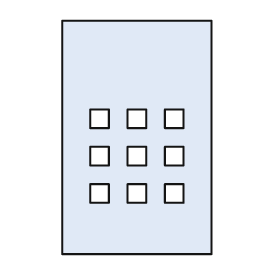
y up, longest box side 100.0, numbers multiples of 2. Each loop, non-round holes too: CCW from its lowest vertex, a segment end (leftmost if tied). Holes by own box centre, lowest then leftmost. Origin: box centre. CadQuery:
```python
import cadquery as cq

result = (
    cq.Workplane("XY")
    .moveTo(-32.0, -50.0)
    .lineTo(32.0, -50.0)
    .lineTo(32.0, 50.0)
    .lineTo(-32.0, 50.0)
    .close()
    .moveTo(-20.0, -28.0)
    .lineTo(-12.0, -28.0)
    .lineTo(-12.0, -20.0)
    .lineTo(-20.0, -20.0)
    .close()
    .moveTo(-4.0, -28.0)
    .lineTo(4.0, -28.0)
    .lineTo(4.0, -20.0)
    .lineTo(-4.0, -20.0)
    .close()
    .moveTo(12.0, -28.0)
    .lineTo(20.0, -28.0)
    .lineTo(20.0, -20.0)
    .lineTo(12.0, -20.0)
    .close()
    .moveTo(-20.0, -12.0)
    .lineTo(-12.0, -12.0)
    .lineTo(-12.0, -4.0)
    .lineTo(-20.0, -4.0)
    .close()
    .moveTo(-4.0, -12.0)
    .lineTo(4.0, -12.0)
    .lineTo(4.0, -4.0)
    .lineTo(-4.0, -4.0)
    .close()
    .moveTo(12.0, -12.0)
    .lineTo(20.0, -12.0)
    .lineTo(20.0, -4.0)
    .lineTo(12.0, -4.0)
    .close()
    .moveTo(-20.0, 4.0)
    .lineTo(-12.0, 4.0)
    .lineTo(-12.0, 12.0)
    .lineTo(-20.0, 12.0)
    .close()
    .moveTo(-4.0, 4.0)
    .lineTo(4.0, 4.0)
    .lineTo(4.0, 12.0)
    .lineTo(-4.0, 12.0)
    .close()
    .moveTo(12.0, 4.0)
    .lineTo(20.0, 4.0)
    .lineTo(20.0, 12.0)
    .lineTo(12.0, 12.0)
    .close()
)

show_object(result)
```